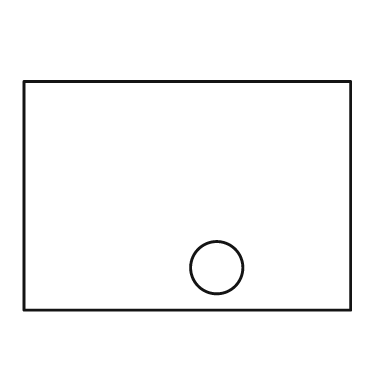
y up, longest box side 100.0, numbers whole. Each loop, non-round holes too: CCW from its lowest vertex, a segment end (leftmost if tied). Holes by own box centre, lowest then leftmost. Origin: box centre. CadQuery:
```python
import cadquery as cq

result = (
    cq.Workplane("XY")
    .moveTo(-50.0, -35.0)
    .lineTo(50.0, -35.0)
    .lineTo(50.0, 35.0)
    .lineTo(-50.0, 35.0)
    .close()
    .moveTo(9.0, -22.0)
    .circle(8.0)
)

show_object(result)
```